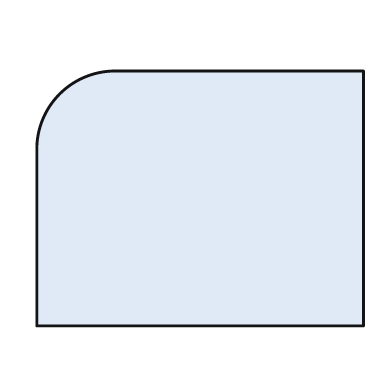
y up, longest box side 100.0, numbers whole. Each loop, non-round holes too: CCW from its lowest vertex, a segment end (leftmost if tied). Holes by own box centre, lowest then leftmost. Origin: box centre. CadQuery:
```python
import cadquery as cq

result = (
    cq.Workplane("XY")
    .moveTo(-50.0, -39.0)
    .lineTo(50.0, -39.0)
    .lineTo(50.0, 39.0)
    .lineTo(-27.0, 39.0)
    .threePointArc((-43.0, 32.0), (-50.0, 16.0))
    .close()
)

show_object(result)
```